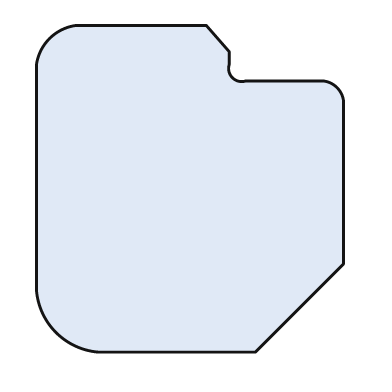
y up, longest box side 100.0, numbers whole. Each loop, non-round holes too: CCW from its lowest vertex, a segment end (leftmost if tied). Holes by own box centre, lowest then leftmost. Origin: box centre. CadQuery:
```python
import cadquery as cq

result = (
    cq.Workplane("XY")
    .moveTo(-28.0, -50.0)
    .lineTo(20.0, -50.0)
    .lineTo(47.0, -23.0)
    .lineTo(47.0, 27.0)
    .threePointArc((45.0, 31.0), (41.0, 33.0))
    .lineTo(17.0, 33.0)
    .threePointArc((13.0, 34.0), (12.0, 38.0))
    .lineTo(12.0, 42.0)
    .lineTo(5.0, 50.0)
    .lineTo(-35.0, 50.0)
    .threePointArc((-43.0, 46.0), (-47.0, 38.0))
    .lineTo(-47.0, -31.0)
    .threePointArc((-41.0, -44.0), (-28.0, -50.0))
    .close()
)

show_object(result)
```